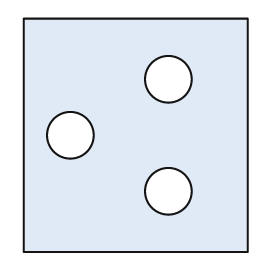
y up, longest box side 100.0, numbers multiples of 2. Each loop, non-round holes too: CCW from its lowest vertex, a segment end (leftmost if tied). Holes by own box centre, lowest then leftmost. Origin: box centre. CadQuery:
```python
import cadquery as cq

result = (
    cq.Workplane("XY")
    .moveTo(-48.0, -50.0)
    .lineTo(48.0, -50.0)
    .lineTo(48.0, 50.0)
    .lineTo(-48.0, 50.0)
    .close()
    .moveTo(14.0, -24.0)
    .circle(10.0)
    .moveTo(-28.0, 0.0)
    .circle(10.0)
    .moveTo(14.0, 24.0)
    .circle(10.0)
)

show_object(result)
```